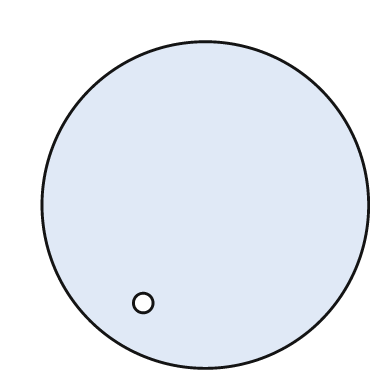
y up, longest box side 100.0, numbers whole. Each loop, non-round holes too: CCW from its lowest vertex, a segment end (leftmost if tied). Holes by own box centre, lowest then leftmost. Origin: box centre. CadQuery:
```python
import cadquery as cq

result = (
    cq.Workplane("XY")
    .moveTo(0.0, 0.0)
    .circle(50.0)
    .moveTo(-19.0, -30.0)
    .circle(3.0)
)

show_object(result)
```